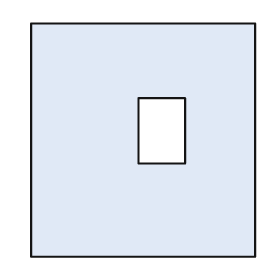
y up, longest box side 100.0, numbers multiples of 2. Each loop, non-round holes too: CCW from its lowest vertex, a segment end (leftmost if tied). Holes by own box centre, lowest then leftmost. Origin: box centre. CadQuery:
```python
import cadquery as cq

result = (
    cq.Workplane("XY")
    .moveTo(-48.0, -50.0)
    .lineTo(48.0, -50.0)
    .lineTo(48.0, 50.0)
    .lineTo(-48.0, 50.0)
    .close()
    .moveTo(-2.0, -10.0)
    .lineTo(18.0, -10.0)
    .lineTo(18.0, 18.0)
    .lineTo(-2.0, 18.0)
    .close()
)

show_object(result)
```